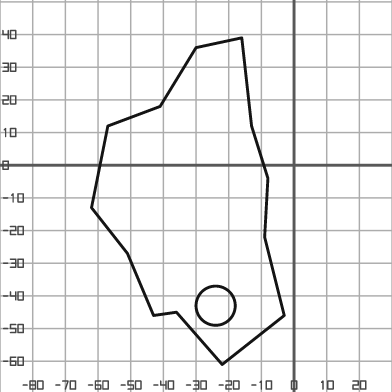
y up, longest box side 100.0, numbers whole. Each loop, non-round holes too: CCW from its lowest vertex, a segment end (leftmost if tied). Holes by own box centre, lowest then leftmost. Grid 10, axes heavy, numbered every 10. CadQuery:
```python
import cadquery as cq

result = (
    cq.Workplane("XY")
    .moveTo(-22.0, -61.0)
    .lineTo(-3.0, -46.0)
    .lineTo(-9.0, -22.0)
    .lineTo(-8.0, -4.0)
    .lineTo(-13.0, 12.0)
    .lineTo(-16.0, 39.0)
    .lineTo(-30.0, 36.0)
    .lineTo(-41.0, 18.0)
    .lineTo(-57.0, 12.0)
    .lineTo(-62.0, -13.0)
    .lineTo(-51.0, -27.0)
    .lineTo(-43.0, -46.0)
    .lineTo(-36.0, -45.0)
    .close()
    .moveTo(-24.0, -43.0)
    .circle(6.0)
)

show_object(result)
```